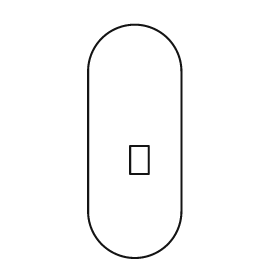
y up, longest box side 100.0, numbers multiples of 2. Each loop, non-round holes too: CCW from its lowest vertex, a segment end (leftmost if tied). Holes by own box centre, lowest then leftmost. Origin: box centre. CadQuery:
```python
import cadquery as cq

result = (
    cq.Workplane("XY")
    .moveTo(-20.0, -30.0)
    .threePointArc((0.0, -50.0), (20.0, -30.0))
    .lineTo(20.0, 30.0)
    .threePointArc((0.0, 50.0), (-20.0, 30.0))
    .close()
    .moveTo(-2.0, -14.0)
    .lineTo(6.0, -14.0)
    .lineTo(6.0, -2.0)
    .lineTo(-2.0, -2.0)
    .close()
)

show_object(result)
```